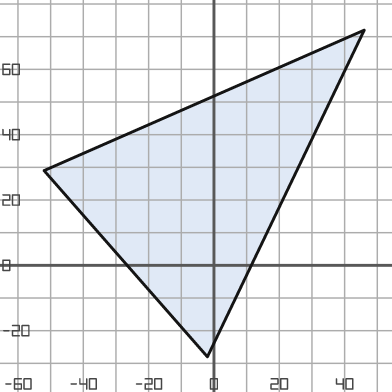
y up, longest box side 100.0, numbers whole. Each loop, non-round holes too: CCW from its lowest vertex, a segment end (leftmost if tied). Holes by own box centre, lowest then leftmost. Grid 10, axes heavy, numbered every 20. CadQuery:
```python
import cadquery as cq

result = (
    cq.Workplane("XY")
    .moveTo(-2.0, -28.0)
    .lineTo(46.0, 72.0)
    .lineTo(-52.0, 29.0)
    .close()
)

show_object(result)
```